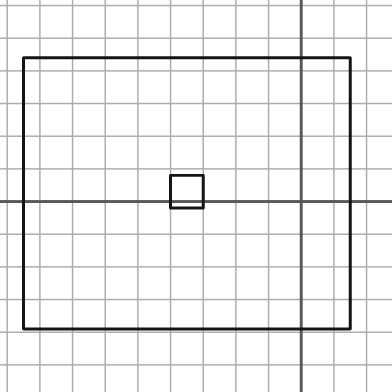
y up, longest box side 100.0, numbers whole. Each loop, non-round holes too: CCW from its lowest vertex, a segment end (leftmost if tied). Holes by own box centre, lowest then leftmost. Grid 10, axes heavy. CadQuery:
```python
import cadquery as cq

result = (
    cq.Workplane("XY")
    .moveTo(-85.0, -39.0)
    .lineTo(15.0, -39.0)
    .lineTo(15.0, 44.0)
    .lineTo(-85.0, 44.0)
    .close()
    .moveTo(-40.0, -2.0)
    .lineTo(-30.0, -2.0)
    .lineTo(-30.0, 8.0)
    .lineTo(-40.0, 8.0)
    .close()
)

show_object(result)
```